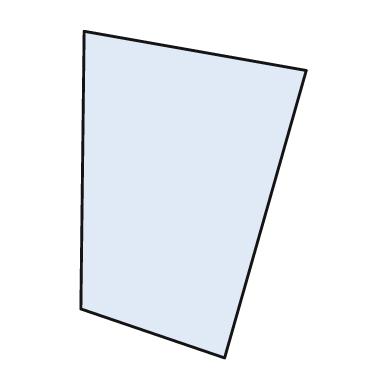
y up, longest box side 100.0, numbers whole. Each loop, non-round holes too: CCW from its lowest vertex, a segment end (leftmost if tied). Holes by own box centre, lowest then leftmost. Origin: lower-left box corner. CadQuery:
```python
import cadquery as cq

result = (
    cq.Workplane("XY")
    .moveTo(44.0, 0.0)
    .lineTo(69.0, 88.0)
    .lineTo(1.0, 100.0)
    .lineTo(0.0, 15.0)
    .close()
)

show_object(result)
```